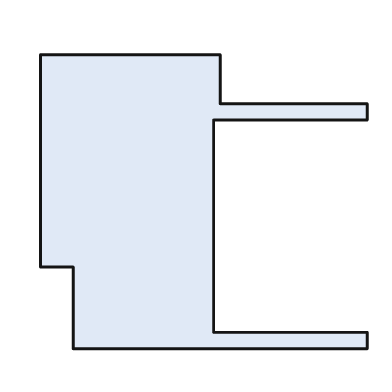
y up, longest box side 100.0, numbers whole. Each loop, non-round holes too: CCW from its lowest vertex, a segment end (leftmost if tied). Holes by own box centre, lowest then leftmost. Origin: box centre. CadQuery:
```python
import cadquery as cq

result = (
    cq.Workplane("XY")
    .moveTo(-40.0, -45.0)
    .lineTo(50.0, -45.0)
    .lineTo(50.0, -40.0)
    .lineTo(3.0, -40.0)
    .lineTo(3.0, 25.0)
    .lineTo(50.0, 25.0)
    .lineTo(50.0, 30.0)
    .lineTo(5.0, 30.0)
    .lineTo(5.0, 45.0)
    .lineTo(-50.0, 45.0)
    .lineTo(-50.0, -20.0)
    .lineTo(-40.0, -20.0)
    .close()
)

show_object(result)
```